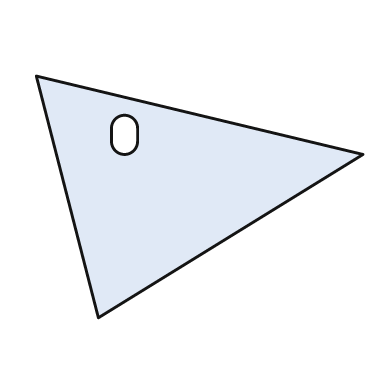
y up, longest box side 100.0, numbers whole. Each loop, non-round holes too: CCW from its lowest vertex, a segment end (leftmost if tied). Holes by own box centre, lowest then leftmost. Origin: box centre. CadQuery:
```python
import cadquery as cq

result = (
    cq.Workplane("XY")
    .moveTo(-31.0, -37.0)
    .lineTo(50.0, 13.0)
    .lineTo(-50.0, 37.0)
    .close()
    .moveTo(-27.0, 17.0)
    .threePointArc((-23.0, 13.0), (-19.0, 17.0))
    .lineTo(-19.0, 21.0)
    .threePointArc((-23.0, 25.0), (-27.0, 21.0))
    .close()
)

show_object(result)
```